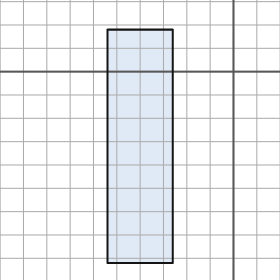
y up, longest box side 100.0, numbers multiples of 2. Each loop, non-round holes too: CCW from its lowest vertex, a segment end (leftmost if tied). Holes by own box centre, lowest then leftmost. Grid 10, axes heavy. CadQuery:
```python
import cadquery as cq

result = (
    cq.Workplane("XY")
    .moveTo(-54.0, -82.0)
    .lineTo(-26.0, -82.0)
    .lineTo(-26.0, 18.0)
    .lineTo(-54.0, 18.0)
    .close()
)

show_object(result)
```